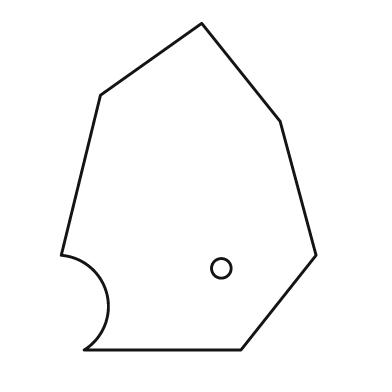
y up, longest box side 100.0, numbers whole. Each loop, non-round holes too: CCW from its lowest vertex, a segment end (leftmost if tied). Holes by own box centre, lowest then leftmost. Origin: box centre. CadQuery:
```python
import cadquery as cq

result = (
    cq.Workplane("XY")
    .moveTo(-32.0, -50.0)
    .lineTo(16.0, -50.0)
    .lineTo(39.0, -21.0)
    .lineTo(28.0, 20.0)
    .lineTo(4.0, 50.0)
    .lineTo(-27.0, 28.0)
    .lineTo(-39.0, -21.0)
    .threePointArc((-25.0, -33.0), (-32.0, -50.0))
    .close()
    .moveTo(10.0, -25.0)
    .circle(3.0)
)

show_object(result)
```